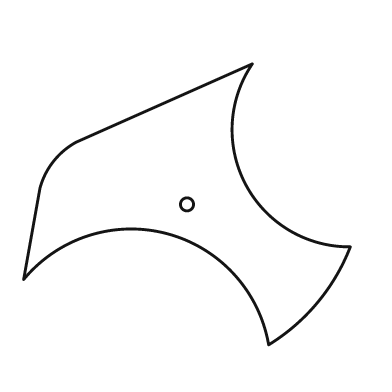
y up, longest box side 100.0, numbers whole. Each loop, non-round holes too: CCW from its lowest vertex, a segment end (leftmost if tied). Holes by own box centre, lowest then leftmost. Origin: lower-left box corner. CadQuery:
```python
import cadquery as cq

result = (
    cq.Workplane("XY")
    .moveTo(75.0, 0.0)
    .threePointArc((90.0, 13.0), (100.0, 30.0))
    .threePointArc((68.0, 49.0), (70.0, 86.0))
    .lineTo(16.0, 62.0)
    .threePointArc((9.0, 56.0), (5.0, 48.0))
    .lineTo(0.0, 20.0)
    .threePointArc((44.0, 34.0), (75.0, 0.0))
    .close()
    .moveTo(50.0, 43.0)
    .circle(2.0)
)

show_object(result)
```